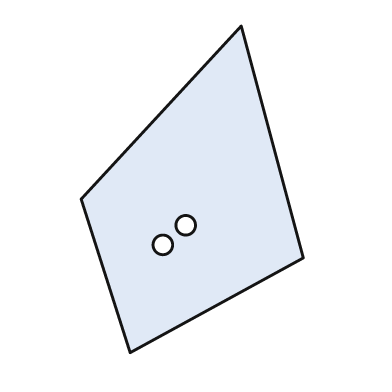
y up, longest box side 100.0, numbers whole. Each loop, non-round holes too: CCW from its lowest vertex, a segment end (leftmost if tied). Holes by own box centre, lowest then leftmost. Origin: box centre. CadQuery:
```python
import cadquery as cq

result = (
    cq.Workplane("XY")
    .moveTo(-19.0, -50.0)
    .lineTo(34.0, -21.0)
    .lineTo(15.0, 50.0)
    .lineTo(-34.0, -3.0)
    .close()
    .moveTo(-9.0, -17.0)
    .circle(3.0)
    .moveTo(-2.0, -11.0)
    .circle(3.0)
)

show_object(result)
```